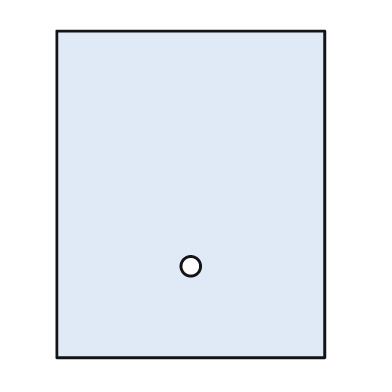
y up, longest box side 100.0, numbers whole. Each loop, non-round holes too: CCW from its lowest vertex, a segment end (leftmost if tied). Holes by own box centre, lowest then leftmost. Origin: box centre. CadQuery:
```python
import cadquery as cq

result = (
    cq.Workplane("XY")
    .moveTo(-41.0, -50.0)
    .lineTo(41.0, -50.0)
    .lineTo(41.0, 50.0)
    .lineTo(-41.0, 50.0)
    .close()
    .moveTo(0.0, -22.0)
    .circle(3.0)
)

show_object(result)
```